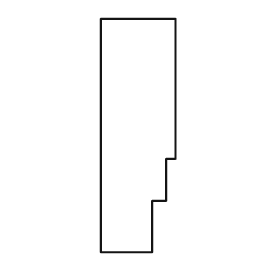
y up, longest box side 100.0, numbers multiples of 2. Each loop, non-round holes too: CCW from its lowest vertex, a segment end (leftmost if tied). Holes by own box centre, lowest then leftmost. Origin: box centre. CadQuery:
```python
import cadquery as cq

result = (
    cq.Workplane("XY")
    .moveTo(-16.0, -50.0)
    .lineTo(6.0, -50.0)
    .lineTo(6.0, -28.0)
    .lineTo(12.0, -28.0)
    .lineTo(12.0, -10.0)
    .lineTo(16.0, -10.0)
    .lineTo(16.0, 50.0)
    .lineTo(-16.0, 50.0)
    .close()
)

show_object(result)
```